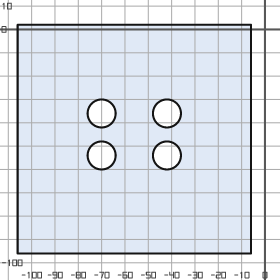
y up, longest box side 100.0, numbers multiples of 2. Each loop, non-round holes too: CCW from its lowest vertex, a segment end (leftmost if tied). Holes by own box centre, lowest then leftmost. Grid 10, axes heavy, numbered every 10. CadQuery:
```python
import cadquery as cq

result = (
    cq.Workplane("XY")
    .moveTo(-106.0, -96.0)
    .lineTo(-6.0, -96.0)
    .lineTo(-6.0, 2.0)
    .lineTo(-106.0, 2.0)
    .close()
    .moveTo(-70.0, -54.0)
    .circle(6.0)
    .moveTo(-42.0, -54.0)
    .circle(6.0)
    .moveTo(-70.0, -36.0)
    .circle(6.0)
    .moveTo(-42.0, -36.0)
    .circle(6.0)
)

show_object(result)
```